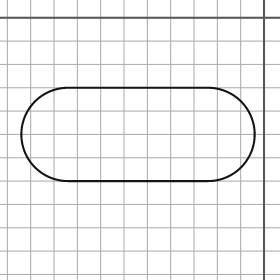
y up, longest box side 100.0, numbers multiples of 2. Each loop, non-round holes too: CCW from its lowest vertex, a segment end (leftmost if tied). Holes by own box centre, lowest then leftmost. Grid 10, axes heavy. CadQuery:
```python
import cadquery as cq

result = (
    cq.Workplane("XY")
    .moveTo(-84.0, -70.0)
    .lineTo(-24.0, -70.0)
    .threePointArc((-4.0, -50.0), (-24.0, -30.0))
    .lineTo(-84.0, -30.0)
    .threePointArc((-104.0, -50.0), (-84.0, -70.0))
    .close()
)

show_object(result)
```